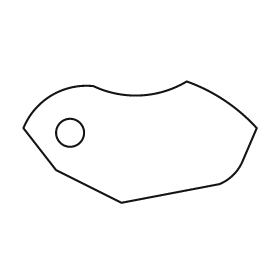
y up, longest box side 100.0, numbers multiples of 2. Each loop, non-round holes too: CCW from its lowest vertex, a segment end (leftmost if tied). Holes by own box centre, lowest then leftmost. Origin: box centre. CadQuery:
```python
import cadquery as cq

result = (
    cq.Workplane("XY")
    .moveTo(-8.0, -26.0)
    .lineTo(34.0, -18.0)
    .threePointArc((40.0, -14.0), (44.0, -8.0))
    .lineTo(50.0, 6.0)
    .threePointArc((36.0, 18.0), (20.0, 26.0))
    .threePointArc((0.0, 20.0), (-20.0, 24.0))
    .threePointArc((-38.0, 20.0), (-50.0, 6.0))
    .lineTo(-36.0, -12.0)
    .close()
    .moveTo(-30.0, 4.0)
    .circle(6.0)
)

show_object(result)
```